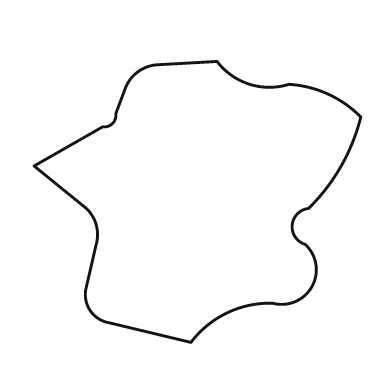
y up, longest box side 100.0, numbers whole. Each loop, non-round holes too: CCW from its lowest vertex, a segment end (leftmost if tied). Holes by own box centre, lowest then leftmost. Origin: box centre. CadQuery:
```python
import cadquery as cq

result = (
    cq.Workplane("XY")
    .moveTo(-2.0, -43.0)
    .threePointArc((9.0, -34.0), (23.0, -31.0))
    .threePointArc((35.0, -26.0), (33.0, -13.0))
    .threePointArc((29.0, -7.0), (34.0, -2.0))
    .threePointArc((44.0, 11.0), (50.0, 26.0))
    .threePointArc((40.0, 33.0), (28.0, 36.0))
    .threePointArc((16.0, 36.0), (6.0, 43.0))
    .lineTo(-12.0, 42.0)
    .threePointArc((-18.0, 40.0), (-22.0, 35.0))
    .lineTo(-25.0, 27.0)
    .threePointArc((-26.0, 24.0), (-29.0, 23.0))
    .lineTo(-50.0, 11.0)
    .lineTo(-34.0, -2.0)
    .threePointArc((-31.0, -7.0), (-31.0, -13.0))
    .lineTo(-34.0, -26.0)
    .threePointArc((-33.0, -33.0), (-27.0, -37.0))
    .close()
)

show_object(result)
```